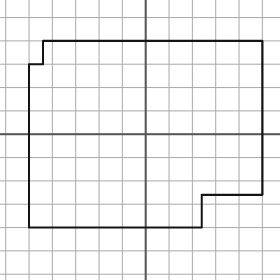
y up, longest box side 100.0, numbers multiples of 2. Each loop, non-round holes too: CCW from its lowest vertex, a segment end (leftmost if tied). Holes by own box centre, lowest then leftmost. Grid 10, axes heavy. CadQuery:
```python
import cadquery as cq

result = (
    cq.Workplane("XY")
    .moveTo(-50.0, -40.0)
    .lineTo(24.0, -40.0)
    .lineTo(24.0, -26.0)
    .lineTo(50.0, -26.0)
    .lineTo(50.0, 40.0)
    .lineTo(-44.0, 40.0)
    .lineTo(-44.0, 30.0)
    .lineTo(-50.0, 30.0)
    .close()
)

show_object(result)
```